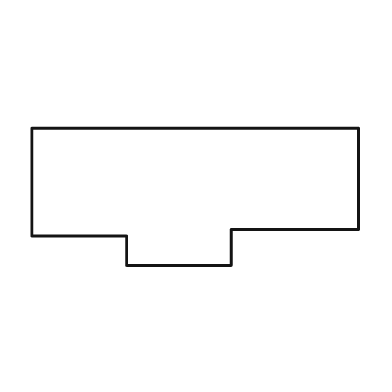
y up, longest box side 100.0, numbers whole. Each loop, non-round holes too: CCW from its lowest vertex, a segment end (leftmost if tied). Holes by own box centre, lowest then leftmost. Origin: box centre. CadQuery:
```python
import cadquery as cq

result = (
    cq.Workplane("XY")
    .moveTo(-21.0, -21.0)
    .lineTo(11.0, -21.0)
    .lineTo(11.0, -10.0)
    .lineTo(50.0, -10.0)
    .lineTo(50.0, 21.0)
    .lineTo(-50.0, 21.0)
    .lineTo(-50.0, -12.0)
    .lineTo(-21.0, -12.0)
    .close()
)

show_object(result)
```